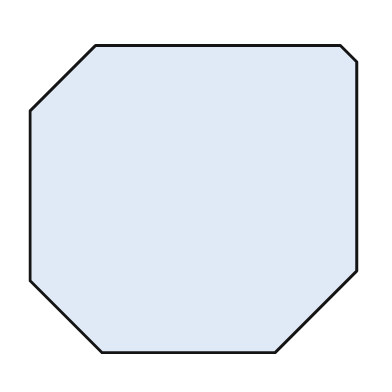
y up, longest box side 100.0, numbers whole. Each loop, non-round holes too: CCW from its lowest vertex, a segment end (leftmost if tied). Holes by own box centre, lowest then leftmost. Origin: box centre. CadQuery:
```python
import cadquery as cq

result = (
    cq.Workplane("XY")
    .moveTo(-28.0, -47.0)
    .lineTo(25.0, -47.0)
    .lineTo(50.0, -22.0)
    .lineTo(50.0, 42.0)
    .lineTo(45.0, 47.0)
    .lineTo(-30.0, 47.0)
    .lineTo(-50.0, 27.0)
    .lineTo(-50.0, -25.0)
    .close()
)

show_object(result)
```